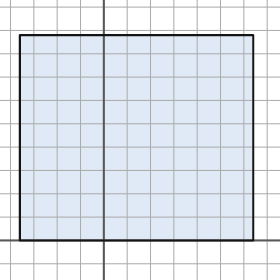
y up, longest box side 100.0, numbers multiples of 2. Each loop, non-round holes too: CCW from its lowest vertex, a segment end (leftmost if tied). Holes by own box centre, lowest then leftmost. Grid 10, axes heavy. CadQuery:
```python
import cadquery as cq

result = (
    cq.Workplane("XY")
    .moveTo(-36.0, 0.0)
    .lineTo(64.0, 0.0)
    .lineTo(64.0, 88.0)
    .lineTo(-36.0, 88.0)
    .close()
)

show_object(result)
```